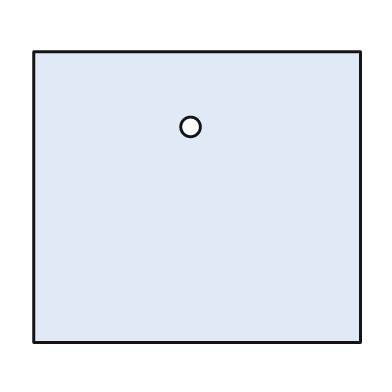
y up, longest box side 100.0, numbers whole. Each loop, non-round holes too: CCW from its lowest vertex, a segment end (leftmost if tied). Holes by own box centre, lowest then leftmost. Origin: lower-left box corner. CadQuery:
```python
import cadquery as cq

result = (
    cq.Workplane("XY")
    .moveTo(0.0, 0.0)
    .lineTo(100.0, 0.0)
    .lineTo(100.0, 89.0)
    .lineTo(0.0, 89.0)
    .close()
    .moveTo(48.0, 66.0)
    .circle(3.0)
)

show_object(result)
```